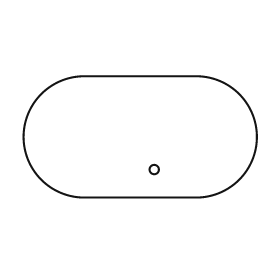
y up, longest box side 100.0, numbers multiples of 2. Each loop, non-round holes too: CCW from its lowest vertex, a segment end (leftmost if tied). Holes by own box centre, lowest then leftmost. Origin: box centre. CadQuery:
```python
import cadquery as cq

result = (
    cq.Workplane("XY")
    .moveTo(-24.0, -26.0)
    .lineTo(24.0, -26.0)
    .threePointArc((50.0, 0.0), (24.0, 26.0))
    .lineTo(-24.0, 26.0)
    .threePointArc((-50.0, 0.0), (-24.0, -26.0))
    .close()
    .moveTo(6.0, -14.0)
    .circle(2.0)
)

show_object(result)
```